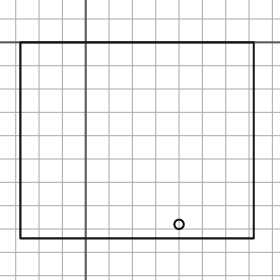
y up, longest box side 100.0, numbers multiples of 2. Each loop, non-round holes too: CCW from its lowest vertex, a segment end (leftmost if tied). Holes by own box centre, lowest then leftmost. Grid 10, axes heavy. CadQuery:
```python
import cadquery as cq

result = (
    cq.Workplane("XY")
    .moveTo(-28.0, -84.0)
    .lineTo(72.0, -84.0)
    .lineTo(72.0, 0.0)
    .lineTo(-28.0, 0.0)
    .close()
    .moveTo(40.0, -78.0)
    .circle(2.0)
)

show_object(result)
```